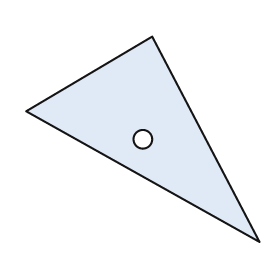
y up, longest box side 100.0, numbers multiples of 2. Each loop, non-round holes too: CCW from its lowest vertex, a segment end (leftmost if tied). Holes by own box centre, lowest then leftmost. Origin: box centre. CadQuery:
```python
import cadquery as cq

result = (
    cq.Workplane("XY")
    .moveTo(50.0, -44.0)
    .lineTo(4.0, 44.0)
    .lineTo(-50.0, 12.0)
    .close()
    .moveTo(0.0, 0.0)
    .circle(4.0)
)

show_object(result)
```